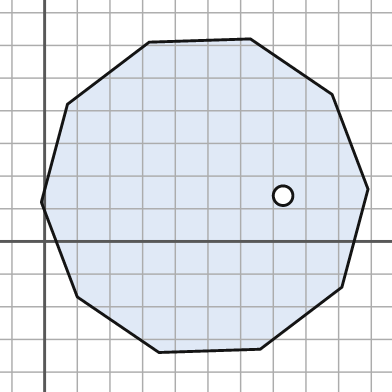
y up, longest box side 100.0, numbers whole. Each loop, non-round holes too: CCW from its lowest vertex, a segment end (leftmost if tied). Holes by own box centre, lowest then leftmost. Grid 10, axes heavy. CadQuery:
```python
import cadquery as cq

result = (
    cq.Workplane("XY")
    .moveTo(35.0, -34.0)
    .lineTo(66.0, -33.0)
    .lineTo(91.0, -14.0)
    .lineTo(99.0, 16.0)
    .lineTo(88.0, 45.0)
    .lineTo(63.0, 62.0)
    .lineTo(32.0, 61.0)
    .lineTo(7.0, 42.0)
    .lineTo(-1.0, 12.0)
    .lineTo(10.0, -17.0)
    .close()
    .moveTo(73.0, 14.0)
    .circle(3.0)
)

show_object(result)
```